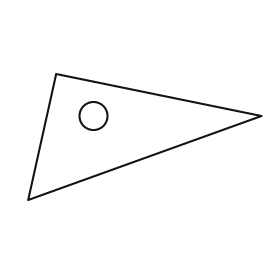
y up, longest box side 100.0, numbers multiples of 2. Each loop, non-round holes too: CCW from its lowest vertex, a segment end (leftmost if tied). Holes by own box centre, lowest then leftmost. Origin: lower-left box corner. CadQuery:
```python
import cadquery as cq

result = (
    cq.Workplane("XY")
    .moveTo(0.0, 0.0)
    .lineTo(100.0, 36.0)
    .lineTo(12.0, 54.0)
    .close()
    .moveTo(28.0, 36.0)
    .circle(6.0)
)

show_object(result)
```